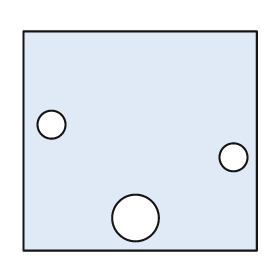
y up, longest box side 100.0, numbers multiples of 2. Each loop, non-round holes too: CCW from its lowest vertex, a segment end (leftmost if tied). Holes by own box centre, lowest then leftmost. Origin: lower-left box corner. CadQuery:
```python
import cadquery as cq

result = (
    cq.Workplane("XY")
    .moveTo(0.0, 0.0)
    .lineTo(100.0, 0.0)
    .lineTo(100.0, 94.0)
    .lineTo(0.0, 94.0)
    .close()
    .moveTo(48.0, 14.0)
    .circle(10.0)
    .moveTo(90.0, 40.0)
    .circle(6.0)
    .moveTo(12.0, 54.0)
    .circle(6.0)
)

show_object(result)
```